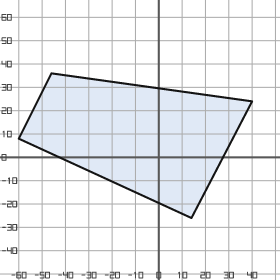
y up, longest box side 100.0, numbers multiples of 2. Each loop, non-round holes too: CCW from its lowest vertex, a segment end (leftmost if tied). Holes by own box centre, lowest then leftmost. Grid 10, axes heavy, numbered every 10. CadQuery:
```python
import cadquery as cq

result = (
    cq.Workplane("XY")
    .moveTo(14.0, -26.0)
    .lineTo(40.0, 24.0)
    .lineTo(-46.0, 36.0)
    .lineTo(-60.0, 8.0)
    .close()
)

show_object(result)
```